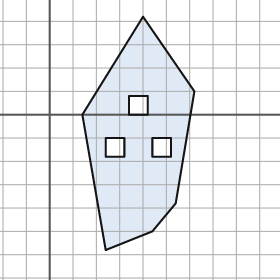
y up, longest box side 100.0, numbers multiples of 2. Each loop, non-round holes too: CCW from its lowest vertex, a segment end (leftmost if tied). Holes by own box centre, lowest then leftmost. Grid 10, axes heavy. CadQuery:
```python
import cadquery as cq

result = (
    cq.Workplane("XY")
    .moveTo(24.0, -58.0)
    .lineTo(44.0, -50.0)
    .lineTo(54.0, -38.0)
    .lineTo(62.0, 10.0)
    .lineTo(40.0, 42.0)
    .lineTo(14.0, 0.0)
    .close()
    .moveTo(24.0, -18.0)
    .lineTo(32.0, -18.0)
    .lineTo(32.0, -10.0)
    .lineTo(24.0, -10.0)
    .close()
    .moveTo(44.0, -18.0)
    .lineTo(52.0, -18.0)
    .lineTo(52.0, -10.0)
    .lineTo(44.0, -10.0)
    .close()
    .moveTo(34.0, 0.0)
    .lineTo(42.0, 0.0)
    .lineTo(42.0, 8.0)
    .lineTo(34.0, 8.0)
    .close()
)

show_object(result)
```